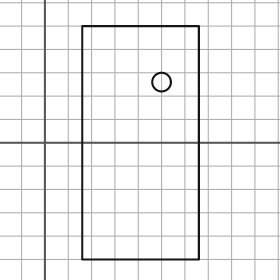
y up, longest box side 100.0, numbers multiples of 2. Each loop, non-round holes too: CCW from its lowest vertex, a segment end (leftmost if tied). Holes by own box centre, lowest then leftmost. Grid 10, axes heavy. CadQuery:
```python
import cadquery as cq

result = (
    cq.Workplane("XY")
    .moveTo(16.0, -50.0)
    .lineTo(66.0, -50.0)
    .lineTo(66.0, 50.0)
    .lineTo(16.0, 50.0)
    .close()
    .moveTo(50.0, 26.0)
    .circle(4.0)
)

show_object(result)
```